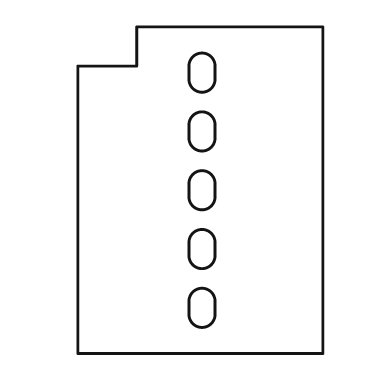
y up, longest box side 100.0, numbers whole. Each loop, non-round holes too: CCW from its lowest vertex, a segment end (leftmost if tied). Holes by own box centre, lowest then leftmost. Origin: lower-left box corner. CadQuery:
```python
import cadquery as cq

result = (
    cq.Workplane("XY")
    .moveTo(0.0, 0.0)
    .lineTo(75.0, 0.0)
    .lineTo(75.0, 100.0)
    .lineTo(18.0, 100.0)
    .lineTo(18.0, 88.0)
    .lineTo(0.0, 88.0)
    .close()
    .moveTo(34.0, 12.0)
    .threePointArc((38.0, 8.0), (42.0, 12.0))
    .lineTo(42.0, 16.0)
    .threePointArc((38.0, 20.0), (34.0, 16.0))
    .close()
    .moveTo(34.0, 30.0)
    .threePointArc((38.0, 26.0), (42.0, 30.0))
    .lineTo(42.0, 34.0)
    .threePointArc((38.0, 38.0), (34.0, 34.0))
    .close()
    .moveTo(34.0, 48.0)
    .threePointArc((38.0, 44.0), (42.0, 48.0))
    .lineTo(42.0, 52.0)
    .threePointArc((38.0, 56.0), (34.0, 52.0))
    .close()
    .moveTo(34.0, 66.0)
    .threePointArc((38.0, 62.0), (42.0, 66.0))
    .lineTo(42.0, 70.0)
    .threePointArc((38.0, 74.0), (34.0, 70.0))
    .close()
    .moveTo(34.0, 84.0)
    .threePointArc((38.0, 80.0), (42.0, 84.0))
    .lineTo(42.0, 88.0)
    .threePointArc((38.0, 92.0), (34.0, 88.0))
    .close()
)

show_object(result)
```